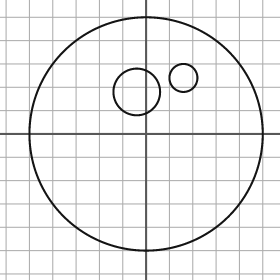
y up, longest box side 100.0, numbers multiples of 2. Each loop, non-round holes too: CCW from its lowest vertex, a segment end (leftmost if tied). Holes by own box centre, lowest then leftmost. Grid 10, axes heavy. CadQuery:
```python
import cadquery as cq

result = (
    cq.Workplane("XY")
    .moveTo(0.0, 0.0)
    .circle(50.0)
    .moveTo(-4.0, 18.0)
    .circle(10.0)
    .moveTo(16.0, 24.0)
    .circle(6.0)
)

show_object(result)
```